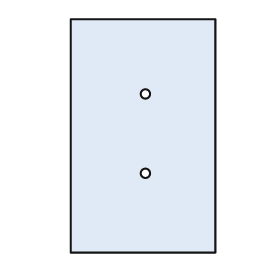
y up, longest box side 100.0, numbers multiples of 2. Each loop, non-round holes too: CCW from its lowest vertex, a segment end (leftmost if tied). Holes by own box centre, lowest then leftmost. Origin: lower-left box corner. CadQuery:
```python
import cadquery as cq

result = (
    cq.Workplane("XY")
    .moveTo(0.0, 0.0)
    .lineTo(62.0, 0.0)
    .lineTo(62.0, 100.0)
    .lineTo(0.0, 100.0)
    .close()
    .moveTo(32.0, 34.0)
    .circle(2.0)
    .moveTo(32.0, 68.0)
    .circle(2.0)
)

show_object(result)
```